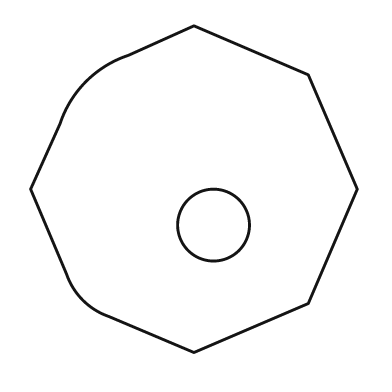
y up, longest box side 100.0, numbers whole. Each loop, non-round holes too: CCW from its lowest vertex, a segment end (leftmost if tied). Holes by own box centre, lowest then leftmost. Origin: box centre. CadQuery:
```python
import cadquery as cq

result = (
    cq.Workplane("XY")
    .moveTo(0.0, -50.0)
    .lineTo(35.0, -35.0)
    .lineTo(50.0, 0.0)
    .lineTo(35.0, 35.0)
    .lineTo(0.0, 50.0)
    .lineTo(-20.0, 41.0)
    .threePointArc((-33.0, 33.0), (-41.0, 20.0))
    .lineTo(-50.0, 0.0)
    .lineTo(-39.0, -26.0)
    .threePointArc((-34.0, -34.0), (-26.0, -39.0))
    .close()
    .moveTo(6.0, -11.0)
    .circle(11.0)
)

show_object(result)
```